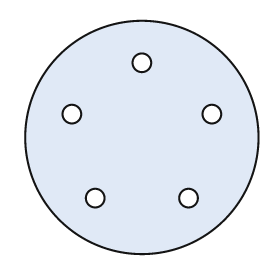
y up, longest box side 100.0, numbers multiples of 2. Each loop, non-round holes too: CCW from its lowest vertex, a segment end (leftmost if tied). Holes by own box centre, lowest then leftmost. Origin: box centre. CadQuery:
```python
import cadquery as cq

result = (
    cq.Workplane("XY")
    .moveTo(0.0, 0.0)
    .circle(50.0)
    .moveTo(-20.0, -26.0)
    .circle(4.0)
    .moveTo(20.0, -26.0)
    .circle(4.0)
    .moveTo(-30.0, 10.0)
    .circle(4.0)
    .moveTo(30.0, 10.0)
    .circle(4.0)
    .moveTo(0.0, 32.0)
    .circle(4.0)
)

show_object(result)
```